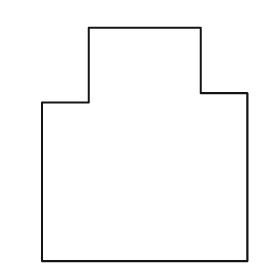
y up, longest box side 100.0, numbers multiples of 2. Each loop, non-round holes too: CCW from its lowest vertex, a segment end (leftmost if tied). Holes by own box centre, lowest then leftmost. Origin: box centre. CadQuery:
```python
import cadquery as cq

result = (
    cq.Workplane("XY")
    .moveTo(-44.0, -50.0)
    .lineTo(44.0, -50.0)
    .lineTo(44.0, 22.0)
    .lineTo(24.0, 22.0)
    .lineTo(24.0, 50.0)
    .lineTo(-24.0, 50.0)
    .lineTo(-24.0, 18.0)
    .lineTo(-44.0, 18.0)
    .close()
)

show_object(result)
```